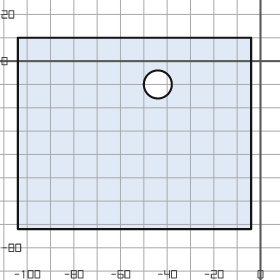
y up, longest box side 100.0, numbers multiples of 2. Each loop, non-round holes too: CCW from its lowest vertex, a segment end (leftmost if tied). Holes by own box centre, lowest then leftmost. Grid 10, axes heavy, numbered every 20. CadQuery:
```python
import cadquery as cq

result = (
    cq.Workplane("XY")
    .moveTo(-104.0, -72.0)
    .lineTo(-4.0, -72.0)
    .lineTo(-4.0, 10.0)
    .lineTo(-104.0, 10.0)
    .close()
    .moveTo(-44.0, -10.0)
    .circle(6.0)
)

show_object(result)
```